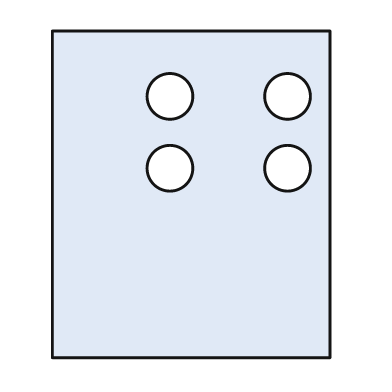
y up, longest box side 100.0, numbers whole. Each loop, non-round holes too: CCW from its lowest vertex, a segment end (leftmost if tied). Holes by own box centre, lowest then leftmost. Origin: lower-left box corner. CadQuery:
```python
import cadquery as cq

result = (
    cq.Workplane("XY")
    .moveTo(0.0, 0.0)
    .lineTo(85.0, 0.0)
    .lineTo(85.0, 100.0)
    .lineTo(0.0, 100.0)
    .close()
    .moveTo(36.0, 58.0)
    .circle(7.0)
    .moveTo(72.0, 58.0)
    .circle(7.0)
    .moveTo(36.0, 80.0)
    .circle(7.0)
    .moveTo(72.0, 80.0)
    .circle(7.0)
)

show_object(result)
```